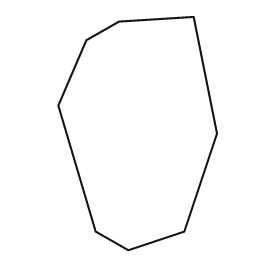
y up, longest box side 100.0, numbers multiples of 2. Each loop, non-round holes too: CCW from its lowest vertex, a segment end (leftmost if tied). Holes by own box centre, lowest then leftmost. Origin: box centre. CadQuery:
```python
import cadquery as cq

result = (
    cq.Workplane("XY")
    .moveTo(-4.0, -50.0)
    .lineTo(20.0, -42.0)
    .lineTo(34.0, 0.0)
    .lineTo(24.0, 50.0)
    .lineTo(-8.0, 48.0)
    .lineTo(-22.0, 40.0)
    .lineTo(-34.0, 12.0)
    .lineTo(-18.0, -42.0)
    .close()
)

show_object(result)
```